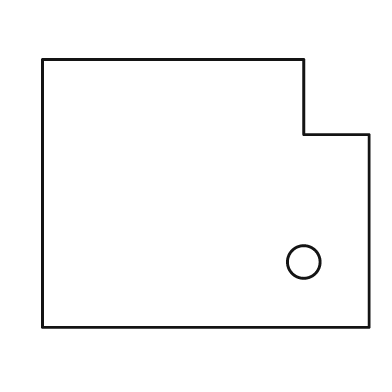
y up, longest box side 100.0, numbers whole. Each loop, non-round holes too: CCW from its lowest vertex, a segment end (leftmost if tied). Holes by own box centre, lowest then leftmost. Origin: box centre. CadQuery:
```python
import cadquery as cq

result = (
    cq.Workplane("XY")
    .moveTo(-50.0, -41.0)
    .lineTo(50.0, -41.0)
    .lineTo(50.0, 18.0)
    .lineTo(30.0, 18.0)
    .lineTo(30.0, 41.0)
    .lineTo(-50.0, 41.0)
    .close()
    .moveTo(30.0, -21.0)
    .circle(5.0)
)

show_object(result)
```